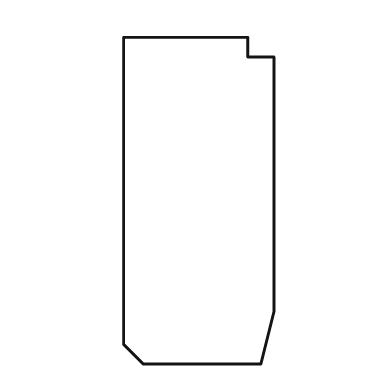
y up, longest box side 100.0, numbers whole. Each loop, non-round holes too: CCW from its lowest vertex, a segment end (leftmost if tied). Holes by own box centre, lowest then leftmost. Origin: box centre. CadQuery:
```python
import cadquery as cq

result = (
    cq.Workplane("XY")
    .moveTo(-17.0, -50.0)
    .lineTo(19.0, -50.0)
    .lineTo(23.0, -34.0)
    .lineTo(23.0, 44.0)
    .lineTo(15.0, 44.0)
    .lineTo(15.0, 50.0)
    .lineTo(-23.0, 50.0)
    .lineTo(-23.0, -44.0)
    .close()
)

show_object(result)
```